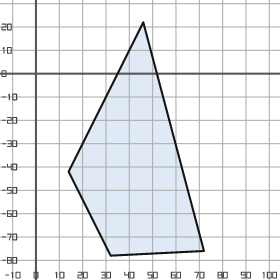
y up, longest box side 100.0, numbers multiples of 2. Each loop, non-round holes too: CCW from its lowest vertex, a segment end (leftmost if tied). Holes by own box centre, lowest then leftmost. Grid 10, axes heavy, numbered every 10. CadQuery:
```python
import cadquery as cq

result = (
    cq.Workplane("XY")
    .moveTo(32.0, -78.0)
    .lineTo(72.0, -76.0)
    .lineTo(46.0, 22.0)
    .lineTo(14.0, -42.0)
    .close()
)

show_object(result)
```